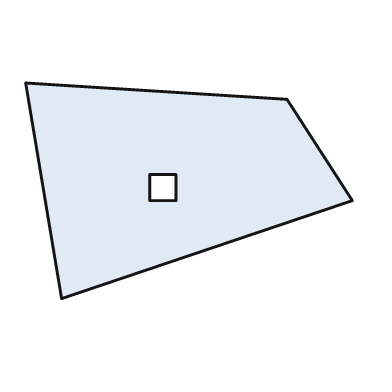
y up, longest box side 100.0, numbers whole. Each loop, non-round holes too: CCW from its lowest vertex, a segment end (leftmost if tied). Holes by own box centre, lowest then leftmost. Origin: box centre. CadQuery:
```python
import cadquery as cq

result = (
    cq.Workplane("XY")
    .moveTo(-39.0, -33.0)
    .lineTo(50.0, -3.0)
    .lineTo(30.0, 28.0)
    .lineTo(-50.0, 33.0)
    .close()
    .moveTo(-12.0, -3.0)
    .lineTo(-4.0, -3.0)
    .lineTo(-4.0, 5.0)
    .lineTo(-12.0, 5.0)
    .close()
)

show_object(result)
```